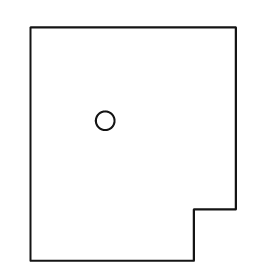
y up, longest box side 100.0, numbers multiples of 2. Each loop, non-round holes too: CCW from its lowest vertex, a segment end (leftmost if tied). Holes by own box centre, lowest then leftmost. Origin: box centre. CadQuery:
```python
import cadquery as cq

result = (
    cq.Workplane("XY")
    .moveTo(-44.0, -50.0)
    .lineTo(26.0, -50.0)
    .lineTo(26.0, -28.0)
    .lineTo(44.0, -28.0)
    .lineTo(44.0, 50.0)
    .lineTo(-44.0, 50.0)
    .close()
    .moveTo(-12.0, 10.0)
    .circle(4.0)
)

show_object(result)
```